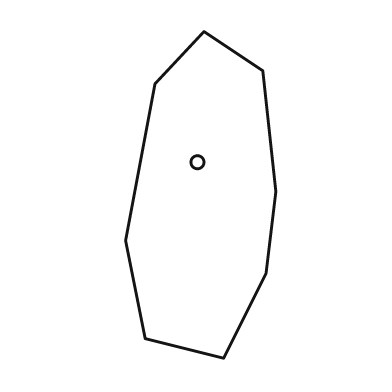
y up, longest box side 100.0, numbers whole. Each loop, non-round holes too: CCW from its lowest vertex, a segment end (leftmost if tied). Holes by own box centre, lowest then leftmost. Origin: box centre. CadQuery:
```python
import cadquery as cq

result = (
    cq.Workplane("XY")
    .moveTo(7.0, -50.0)
    .lineTo(20.0, -24.0)
    .lineTo(23.0, 1.0)
    .lineTo(19.0, 38.0)
    .lineTo(1.0, 50.0)
    .lineTo(-14.0, 34.0)
    .lineTo(-23.0, -14.0)
    .lineTo(-17.0, -44.0)
    .close()
    .moveTo(-1.0, 10.0)
    .circle(2.0)
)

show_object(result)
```